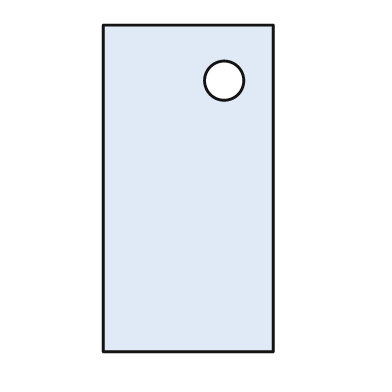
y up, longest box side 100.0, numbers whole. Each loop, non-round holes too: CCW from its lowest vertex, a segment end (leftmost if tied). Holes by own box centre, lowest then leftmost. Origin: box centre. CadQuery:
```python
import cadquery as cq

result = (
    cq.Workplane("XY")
    .moveTo(-26.0, -50.0)
    .lineTo(26.0, -50.0)
    .lineTo(26.0, 50.0)
    .lineTo(-26.0, 50.0)
    .close()
    .moveTo(11.0, 33.0)
    .circle(6.0)
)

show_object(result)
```